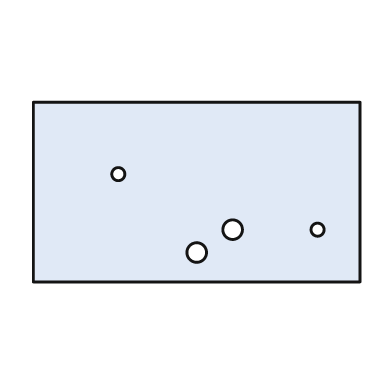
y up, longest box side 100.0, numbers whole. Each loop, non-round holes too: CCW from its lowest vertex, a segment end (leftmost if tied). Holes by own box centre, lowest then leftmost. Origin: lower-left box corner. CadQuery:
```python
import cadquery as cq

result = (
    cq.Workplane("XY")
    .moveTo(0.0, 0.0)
    .lineTo(100.0, 0.0)
    .lineTo(100.0, 55.0)
    .lineTo(0.0, 55.0)
    .close()
    .moveTo(50.0, 9.0)
    .circle(3.0)
    .moveTo(61.0, 16.0)
    .circle(3.0)
    .moveTo(87.0, 16.0)
    .circle(2.0)
    .moveTo(26.0, 33.0)
    .circle(2.0)
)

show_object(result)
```